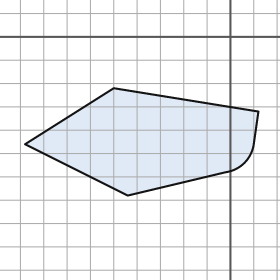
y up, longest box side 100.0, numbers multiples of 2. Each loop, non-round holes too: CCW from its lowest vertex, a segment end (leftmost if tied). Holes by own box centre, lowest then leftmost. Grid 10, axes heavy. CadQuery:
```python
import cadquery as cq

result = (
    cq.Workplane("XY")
    .moveTo(-44.0, -68.0)
    .lineTo(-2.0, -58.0)
    .threePointArc((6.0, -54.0), (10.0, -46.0))
    .lineTo(12.0, -32.0)
    .lineTo(-50.0, -22.0)
    .lineTo(-88.0, -46.0)
    .close()
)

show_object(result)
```